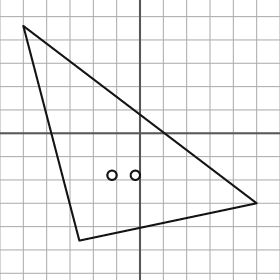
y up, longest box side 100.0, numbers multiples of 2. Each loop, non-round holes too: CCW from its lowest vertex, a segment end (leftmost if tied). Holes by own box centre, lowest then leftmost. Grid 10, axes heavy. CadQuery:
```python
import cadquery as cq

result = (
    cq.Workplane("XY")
    .moveTo(-26.0, -46.0)
    .lineTo(50.0, -30.0)
    .lineTo(-50.0, 46.0)
    .close()
    .moveTo(-12.0, -18.0)
    .circle(2.0)
    .moveTo(-2.0, -18.0)
    .circle(2.0)
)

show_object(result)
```